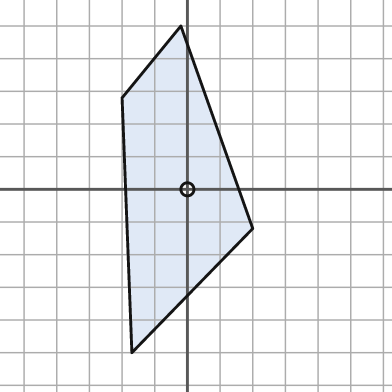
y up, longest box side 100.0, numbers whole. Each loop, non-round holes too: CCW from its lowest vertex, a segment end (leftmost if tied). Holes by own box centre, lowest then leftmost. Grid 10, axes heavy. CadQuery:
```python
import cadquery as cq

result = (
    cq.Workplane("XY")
    .moveTo(-17.0, -50.0)
    .lineTo(20.0, -12.0)
    .lineTo(-2.0, 50.0)
    .lineTo(-20.0, 28.0)
    .close()
    .moveTo(0.0, 0.0)
    .circle(2.0)
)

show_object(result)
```